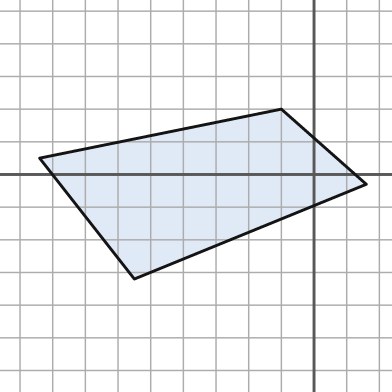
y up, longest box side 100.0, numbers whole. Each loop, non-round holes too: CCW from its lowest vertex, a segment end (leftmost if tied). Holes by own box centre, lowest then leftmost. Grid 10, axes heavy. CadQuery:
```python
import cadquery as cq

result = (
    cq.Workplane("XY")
    .moveTo(-55.0, -32.0)
    .lineTo(16.0, -3.0)
    .lineTo(-10.0, 20.0)
    .lineTo(-84.0, 5.0)
    .close()
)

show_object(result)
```